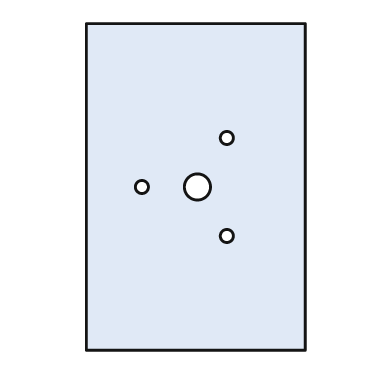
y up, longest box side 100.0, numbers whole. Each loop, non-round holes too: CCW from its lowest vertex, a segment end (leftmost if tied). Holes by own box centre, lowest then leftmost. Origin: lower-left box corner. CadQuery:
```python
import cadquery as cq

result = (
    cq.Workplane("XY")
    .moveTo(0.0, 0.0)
    .lineTo(67.0, 0.0)
    .lineTo(67.0, 100.0)
    .lineTo(0.0, 100.0)
    .close()
    .moveTo(43.0, 35.0)
    .circle(2.0)
    .moveTo(17.0, 50.0)
    .circle(2.0)
    .moveTo(34.0, 50.0)
    .circle(4.0)
    .moveTo(43.0, 65.0)
    .circle(2.0)
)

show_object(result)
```